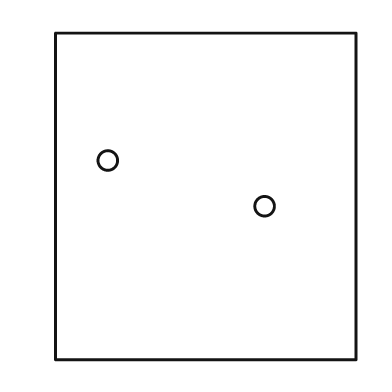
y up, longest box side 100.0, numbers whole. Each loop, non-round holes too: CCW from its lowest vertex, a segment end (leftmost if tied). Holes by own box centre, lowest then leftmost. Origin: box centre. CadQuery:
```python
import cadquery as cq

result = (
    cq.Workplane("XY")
    .moveTo(-46.0, -50.0)
    .lineTo(46.0, -50.0)
    .lineTo(46.0, 50.0)
    .lineTo(-46.0, 50.0)
    .close()
    .moveTo(18.0, -3.0)
    .circle(3.0)
    .moveTo(-30.0, 11.0)
    .circle(3.0)
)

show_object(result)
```